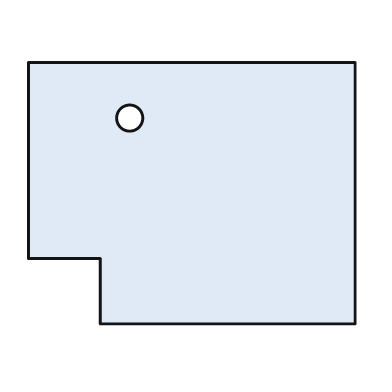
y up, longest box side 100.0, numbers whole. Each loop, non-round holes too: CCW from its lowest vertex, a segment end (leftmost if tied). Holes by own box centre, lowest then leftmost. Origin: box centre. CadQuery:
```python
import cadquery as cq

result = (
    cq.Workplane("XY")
    .moveTo(-28.0, -40.0)
    .lineTo(50.0, -40.0)
    .lineTo(50.0, 40.0)
    .lineTo(-50.0, 40.0)
    .lineTo(-50.0, -20.0)
    .lineTo(-28.0, -20.0)
    .close()
    .moveTo(-19.0, 23.0)
    .circle(4.0)
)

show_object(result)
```